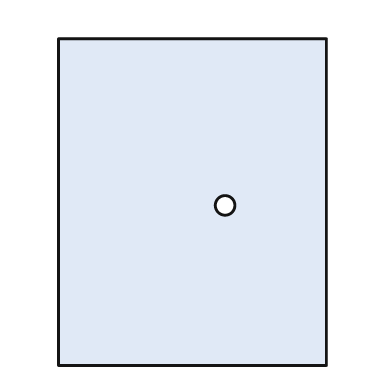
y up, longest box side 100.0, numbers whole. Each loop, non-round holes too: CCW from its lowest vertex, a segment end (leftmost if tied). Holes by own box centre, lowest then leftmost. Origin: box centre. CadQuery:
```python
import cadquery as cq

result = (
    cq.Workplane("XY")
    .moveTo(-41.0, -50.0)
    .lineTo(41.0, -50.0)
    .lineTo(41.0, 50.0)
    .lineTo(-41.0, 50.0)
    .close()
    .moveTo(10.0, -1.0)
    .circle(3.0)
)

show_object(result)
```